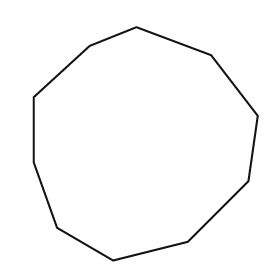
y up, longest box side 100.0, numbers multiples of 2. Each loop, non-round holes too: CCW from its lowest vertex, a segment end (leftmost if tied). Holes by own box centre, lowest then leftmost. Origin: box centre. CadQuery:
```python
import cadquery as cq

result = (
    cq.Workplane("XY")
    .moveTo(-14.0, -50.0)
    .lineTo(18.0, -42.0)
    .lineTo(44.0, -16.0)
    .lineTo(48.0, 12.0)
    .lineTo(28.0, 38.0)
    .lineTo(-4.0, 50.0)
    .lineTo(-24.0, 42.0)
    .lineTo(-48.0, 20.0)
    .lineTo(-48.0, -8.0)
    .lineTo(-38.0, -36.0)
    .close()
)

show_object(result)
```